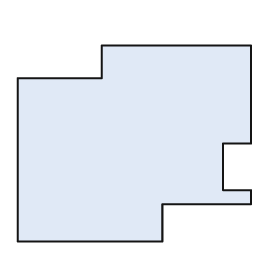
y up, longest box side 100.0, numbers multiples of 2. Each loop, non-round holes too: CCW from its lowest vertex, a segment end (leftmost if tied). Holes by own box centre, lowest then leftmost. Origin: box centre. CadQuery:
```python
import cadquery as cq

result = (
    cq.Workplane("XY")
    .moveTo(-50.0, -42.0)
    .lineTo(12.0, -42.0)
    .lineTo(12.0, -26.0)
    .lineTo(50.0, -26.0)
    .lineTo(50.0, -20.0)
    .lineTo(38.0, -20.0)
    .lineTo(38.0, 0.0)
    .lineTo(50.0, 0.0)
    .lineTo(50.0, 42.0)
    .lineTo(-14.0, 42.0)
    .lineTo(-14.0, 28.0)
    .lineTo(-50.0, 28.0)
    .close()
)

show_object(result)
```